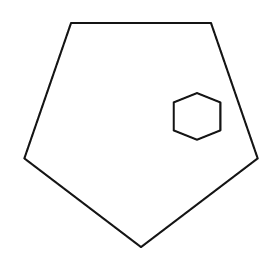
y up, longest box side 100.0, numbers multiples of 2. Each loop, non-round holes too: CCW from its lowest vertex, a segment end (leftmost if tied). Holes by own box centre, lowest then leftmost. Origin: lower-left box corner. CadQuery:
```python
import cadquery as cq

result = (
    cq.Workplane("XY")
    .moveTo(50.0, 0.0)
    .lineTo(100.0, 38.0)
    .lineTo(80.0, 96.0)
    .lineTo(20.0, 96.0)
    .lineTo(0.0, 38.0)
    .close()
    .moveTo(74.0, 46.0)
    .lineTo(84.0, 50.0)
    .lineTo(84.0, 62.0)
    .lineTo(74.0, 66.0)
    .lineTo(64.0, 62.0)
    .lineTo(64.0, 50.0)
    .close()
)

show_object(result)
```